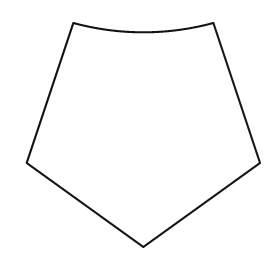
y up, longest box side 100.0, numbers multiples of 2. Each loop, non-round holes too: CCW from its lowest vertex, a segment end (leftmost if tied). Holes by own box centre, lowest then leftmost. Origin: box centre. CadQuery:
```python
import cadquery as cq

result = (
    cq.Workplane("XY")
    .moveTo(0.0, -48.0)
    .lineTo(50.0, -12.0)
    .lineTo(30.0, 48.0)
    .threePointArc((0.0, 44.0), (-30.0, 48.0))
    .lineTo(-50.0, -12.0)
    .close()
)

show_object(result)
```